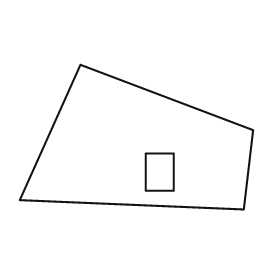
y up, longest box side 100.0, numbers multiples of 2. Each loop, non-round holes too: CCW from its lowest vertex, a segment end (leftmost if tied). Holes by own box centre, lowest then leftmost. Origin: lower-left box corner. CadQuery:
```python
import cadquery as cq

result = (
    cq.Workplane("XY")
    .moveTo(96.0, 0.0)
    .lineTo(100.0, 34.0)
    .lineTo(26.0, 62.0)
    .lineTo(0.0, 4.0)
    .close()
    .moveTo(54.0, 8.0)
    .lineTo(66.0, 8.0)
    .lineTo(66.0, 24.0)
    .lineTo(54.0, 24.0)
    .close()
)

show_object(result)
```